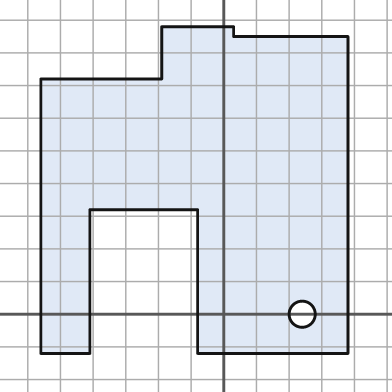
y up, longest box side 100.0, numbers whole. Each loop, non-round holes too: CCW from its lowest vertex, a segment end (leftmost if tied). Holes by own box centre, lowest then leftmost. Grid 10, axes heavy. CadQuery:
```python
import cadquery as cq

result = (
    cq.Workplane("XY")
    .moveTo(-56.0, -12.0)
    .lineTo(-41.0, -12.0)
    .lineTo(-41.0, 32.0)
    .lineTo(-8.0, 32.0)
    .lineTo(-8.0, -12.0)
    .lineTo(38.0, -12.0)
    .lineTo(38.0, 85.0)
    .lineTo(3.0, 85.0)
    .lineTo(3.0, 88.0)
    .lineTo(-19.0, 88.0)
    .lineTo(-19.0, 72.0)
    .lineTo(-56.0, 72.0)
    .close()
    .moveTo(24.0, 0.0)
    .circle(4.0)
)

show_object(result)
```